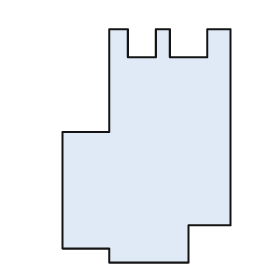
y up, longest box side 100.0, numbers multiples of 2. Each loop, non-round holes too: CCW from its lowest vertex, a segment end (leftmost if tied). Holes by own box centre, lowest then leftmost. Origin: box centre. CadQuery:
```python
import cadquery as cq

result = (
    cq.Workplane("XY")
    .moveTo(-16.0, -50.0)
    .lineTo(18.0, -50.0)
    .lineTo(18.0, -34.0)
    .lineTo(36.0, -34.0)
    .lineTo(36.0, 50.0)
    .lineTo(26.0, 50.0)
    .lineTo(26.0, 38.0)
    .lineTo(10.0, 38.0)
    .lineTo(10.0, 50.0)
    .lineTo(4.0, 50.0)
    .lineTo(4.0, 38.0)
    .lineTo(-8.0, 38.0)
    .lineTo(-8.0, 50.0)
    .lineTo(-16.0, 50.0)
    .lineTo(-16.0, 6.0)
    .lineTo(-36.0, 6.0)
    .lineTo(-36.0, -44.0)
    .lineTo(-16.0, -44.0)
    .close()
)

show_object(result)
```